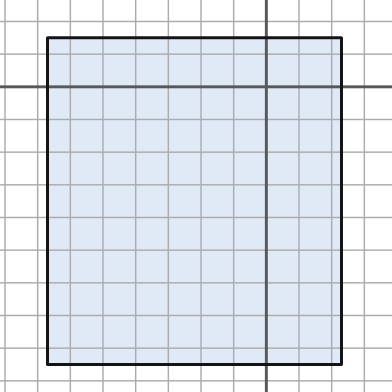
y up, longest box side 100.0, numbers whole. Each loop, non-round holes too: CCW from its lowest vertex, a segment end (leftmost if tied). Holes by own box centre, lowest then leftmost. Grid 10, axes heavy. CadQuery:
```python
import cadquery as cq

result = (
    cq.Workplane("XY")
    .moveTo(-67.0, -85.0)
    .lineTo(23.0, -85.0)
    .lineTo(23.0, 15.0)
    .lineTo(-67.0, 15.0)
    .close()
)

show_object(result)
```